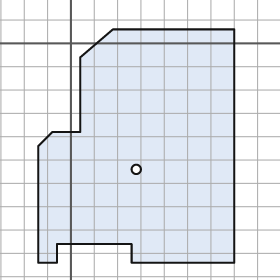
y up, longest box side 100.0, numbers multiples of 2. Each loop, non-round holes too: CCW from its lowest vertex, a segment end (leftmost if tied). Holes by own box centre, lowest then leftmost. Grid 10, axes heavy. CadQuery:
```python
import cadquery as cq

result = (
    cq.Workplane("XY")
    .moveTo(-14.0, -94.0)
    .lineTo(-6.0, -94.0)
    .lineTo(-6.0, -86.0)
    .lineTo(26.0, -86.0)
    .lineTo(26.0, -94.0)
    .lineTo(70.0, -94.0)
    .lineTo(70.0, 6.0)
    .lineTo(18.0, 6.0)
    .lineTo(4.0, -6.0)
    .lineTo(4.0, -38.0)
    .lineTo(-8.0, -38.0)
    .lineTo(-14.0, -44.0)
    .close()
    .moveTo(28.0, -54.0)
    .circle(2.0)
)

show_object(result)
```